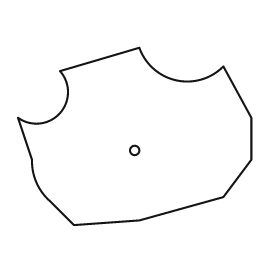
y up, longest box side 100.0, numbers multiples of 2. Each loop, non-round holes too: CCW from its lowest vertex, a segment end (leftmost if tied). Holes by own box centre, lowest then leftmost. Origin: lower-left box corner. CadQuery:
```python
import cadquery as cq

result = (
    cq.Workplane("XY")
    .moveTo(24.0, 0.0)
    .lineTo(52.0, 2.0)
    .lineTo(88.0, 12.0)
    .lineTo(100.0, 28.0)
    .lineTo(100.0, 46.0)
    .lineTo(88.0, 68.0)
    .threePointArc((68.0, 62.0), (52.0, 76.0))
    .lineTo(18.0, 66.0)
    .threePointArc((18.0, 48.0), (0.0, 46.0))
    .lineTo(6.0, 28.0)
    .threePointArc((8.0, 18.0), (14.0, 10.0))
    .close()
    .moveTo(50.0, 32.0)
    .circle(2.0)
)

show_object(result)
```